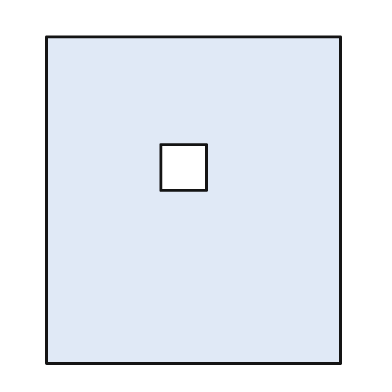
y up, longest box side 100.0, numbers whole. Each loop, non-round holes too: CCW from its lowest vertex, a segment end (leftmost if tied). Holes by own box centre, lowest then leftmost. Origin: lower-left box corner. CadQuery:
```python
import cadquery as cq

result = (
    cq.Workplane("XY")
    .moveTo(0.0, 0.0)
    .lineTo(90.0, 0.0)
    .lineTo(90.0, 100.0)
    .lineTo(0.0, 100.0)
    .close()
    .moveTo(35.0, 53.0)
    .lineTo(49.0, 53.0)
    .lineTo(49.0, 67.0)
    .lineTo(35.0, 67.0)
    .close()
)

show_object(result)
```